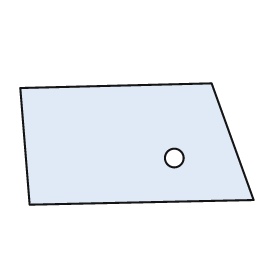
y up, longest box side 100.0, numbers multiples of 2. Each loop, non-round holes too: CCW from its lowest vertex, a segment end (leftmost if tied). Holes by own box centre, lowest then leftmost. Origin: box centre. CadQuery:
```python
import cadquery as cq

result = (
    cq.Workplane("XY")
    .moveTo(-46.0, -26.0)
    .lineTo(50.0, -24.0)
    .lineTo(32.0, 26.0)
    .lineTo(-50.0, 24.0)
    .close()
    .moveTo(16.0, -6.0)
    .circle(4.0)
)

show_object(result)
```